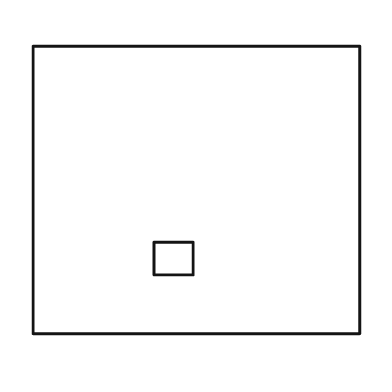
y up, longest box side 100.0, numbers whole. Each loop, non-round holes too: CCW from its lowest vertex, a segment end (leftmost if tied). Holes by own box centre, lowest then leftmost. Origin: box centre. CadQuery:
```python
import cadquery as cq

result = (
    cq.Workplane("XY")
    .moveTo(-50.0, -44.0)
    .lineTo(50.0, -44.0)
    .lineTo(50.0, 44.0)
    .lineTo(-50.0, 44.0)
    .close()
    .moveTo(-13.0, -26.0)
    .lineTo(-1.0, -26.0)
    .lineTo(-1.0, -16.0)
    .lineTo(-13.0, -16.0)
    .close()
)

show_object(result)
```